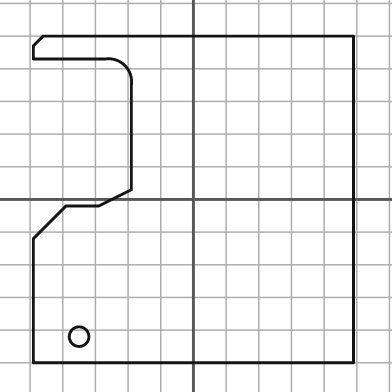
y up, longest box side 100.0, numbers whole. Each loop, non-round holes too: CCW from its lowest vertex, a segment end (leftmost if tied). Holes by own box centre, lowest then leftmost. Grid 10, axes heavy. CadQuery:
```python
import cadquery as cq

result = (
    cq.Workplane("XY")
    .moveTo(-49.0, -50.0)
    .lineTo(49.0, -50.0)
    .lineTo(49.0, 50.0)
    .lineTo(-46.0, 50.0)
    .lineTo(-49.0, 47.0)
    .lineTo(-49.0, 43.0)
    .lineTo(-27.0, 43.0)
    .threePointArc((-21.0, 41.0), (-19.0, 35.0))
    .lineTo(-19.0, 3.0)
    .lineTo(-29.0, -2.0)
    .lineTo(-39.0, -2.0)
    .lineTo(-49.0, -12.0)
    .close()
    .moveTo(-35.0, -42.0)
    .circle(3.0)
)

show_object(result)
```